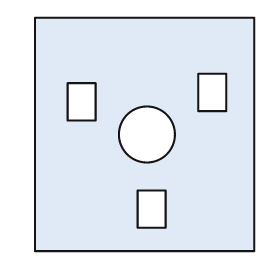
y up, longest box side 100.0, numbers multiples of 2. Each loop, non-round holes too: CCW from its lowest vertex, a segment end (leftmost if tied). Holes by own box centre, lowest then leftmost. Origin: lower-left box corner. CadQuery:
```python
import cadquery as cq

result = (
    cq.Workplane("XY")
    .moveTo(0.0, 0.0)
    .lineTo(94.0, 0.0)
    .lineTo(94.0, 100.0)
    .lineTo(0.0, 100.0)
    .close()
    .moveTo(44.0, 10.0)
    .lineTo(56.0, 10.0)
    .lineTo(56.0, 26.0)
    .lineTo(44.0, 26.0)
    .close()
    .moveTo(48.0, 50.0)
    .circle(12.0)
    .moveTo(14.0, 56.0)
    .lineTo(26.0, 56.0)
    .lineTo(26.0, 72.0)
    .lineTo(14.0, 72.0)
    .close()
    .moveTo(70.0, 60.0)
    .lineTo(82.0, 60.0)
    .lineTo(82.0, 76.0)
    .lineTo(70.0, 76.0)
    .close()
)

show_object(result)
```